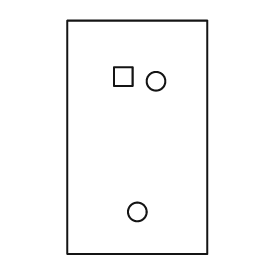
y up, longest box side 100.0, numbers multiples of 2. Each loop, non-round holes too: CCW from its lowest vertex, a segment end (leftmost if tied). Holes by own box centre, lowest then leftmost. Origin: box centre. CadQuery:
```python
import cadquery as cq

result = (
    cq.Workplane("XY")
    .moveTo(-30.0, -50.0)
    .lineTo(30.0, -50.0)
    .lineTo(30.0, 50.0)
    .lineTo(-30.0, 50.0)
    .close()
    .moveTo(0.0, -32.0)
    .circle(4.0)
    .moveTo(8.0, 24.0)
    .circle(4.0)
    .moveTo(-10.0, 22.0)
    .lineTo(-2.0, 22.0)
    .lineTo(-2.0, 30.0)
    .lineTo(-10.0, 30.0)
    .close()
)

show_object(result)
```